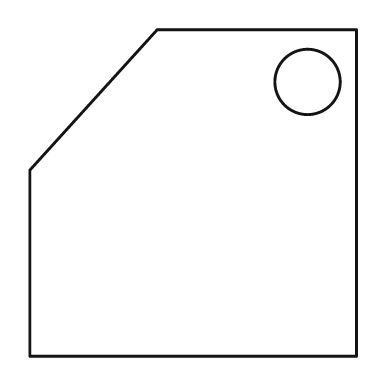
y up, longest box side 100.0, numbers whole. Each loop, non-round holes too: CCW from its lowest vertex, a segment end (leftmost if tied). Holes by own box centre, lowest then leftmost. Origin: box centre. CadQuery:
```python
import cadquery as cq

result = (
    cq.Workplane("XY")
    .moveTo(-50.0, -50.0)
    .lineTo(50.0, -50.0)
    .lineTo(50.0, 50.0)
    .lineTo(-11.0, 50.0)
    .lineTo(-50.0, 7.0)
    .close()
    .moveTo(35.0, 34.0)
    .circle(10.0)
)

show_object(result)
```